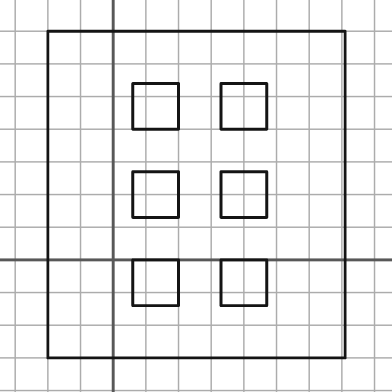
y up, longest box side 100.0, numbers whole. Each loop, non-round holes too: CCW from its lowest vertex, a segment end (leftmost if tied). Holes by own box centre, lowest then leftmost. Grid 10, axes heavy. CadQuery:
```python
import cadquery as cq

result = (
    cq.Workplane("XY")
    .moveTo(-20.0, -30.0)
    .lineTo(71.0, -30.0)
    .lineTo(71.0, 70.0)
    .lineTo(-20.0, 70.0)
    .close()
    .moveTo(6.0, -14.0)
    .lineTo(20.0, -14.0)
    .lineTo(20.0, 0.0)
    .lineTo(6.0, 0.0)
    .close()
    .moveTo(33.0, -14.0)
    .lineTo(47.0, -14.0)
    .lineTo(47.0, 0.0)
    .lineTo(33.0, 0.0)
    .close()
    .moveTo(6.0, 13.0)
    .lineTo(20.0, 13.0)
    .lineTo(20.0, 27.0)
    .lineTo(6.0, 27.0)
    .close()
    .moveTo(33.0, 13.0)
    .lineTo(47.0, 13.0)
    .lineTo(47.0, 27.0)
    .lineTo(33.0, 27.0)
    .close()
    .moveTo(6.0, 40.0)
    .lineTo(20.0, 40.0)
    .lineTo(20.0, 54.0)
    .lineTo(6.0, 54.0)
    .close()
    .moveTo(33.0, 40.0)
    .lineTo(47.0, 40.0)
    .lineTo(47.0, 54.0)
    .lineTo(33.0, 54.0)
    .close()
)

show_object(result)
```